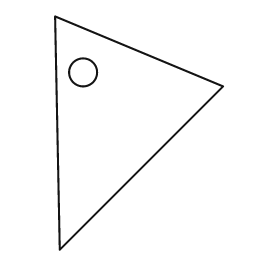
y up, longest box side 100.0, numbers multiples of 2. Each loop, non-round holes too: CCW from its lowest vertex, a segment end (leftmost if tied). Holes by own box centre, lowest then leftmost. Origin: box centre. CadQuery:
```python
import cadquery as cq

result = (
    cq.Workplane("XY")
    .moveTo(-34.0, -50.0)
    .lineTo(36.0, 20.0)
    .lineTo(-36.0, 50.0)
    .close()
    .moveTo(-24.0, 26.0)
    .circle(6.0)
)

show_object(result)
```